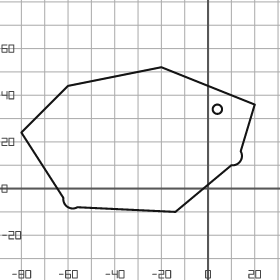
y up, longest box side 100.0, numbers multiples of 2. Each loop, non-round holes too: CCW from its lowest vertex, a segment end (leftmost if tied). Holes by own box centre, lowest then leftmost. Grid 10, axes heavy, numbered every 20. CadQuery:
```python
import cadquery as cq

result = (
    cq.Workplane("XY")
    .moveTo(-14.0, -10.0)
    .lineTo(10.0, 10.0)
    .threePointArc((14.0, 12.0), (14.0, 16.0))
    .lineTo(20.0, 36.0)
    .lineTo(-20.0, 52.0)
    .lineTo(-60.0, 44.0)
    .lineTo(-80.0, 24.0)
    .lineTo(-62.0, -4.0)
    .threePointArc((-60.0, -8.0), (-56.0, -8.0))
    .close()
    .moveTo(4.0, 34.0)
    .circle(2.0)
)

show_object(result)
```